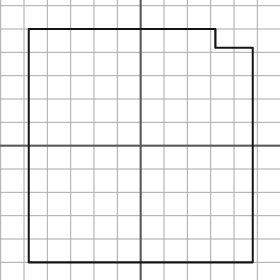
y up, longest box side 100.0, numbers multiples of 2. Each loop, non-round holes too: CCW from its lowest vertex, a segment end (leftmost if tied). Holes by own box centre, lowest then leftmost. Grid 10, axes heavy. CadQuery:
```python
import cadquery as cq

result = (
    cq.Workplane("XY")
    .moveTo(-48.0, -50.0)
    .lineTo(48.0, -50.0)
    .lineTo(48.0, 42.0)
    .lineTo(32.0, 42.0)
    .lineTo(32.0, 50.0)
    .lineTo(-48.0, 50.0)
    .close()
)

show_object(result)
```